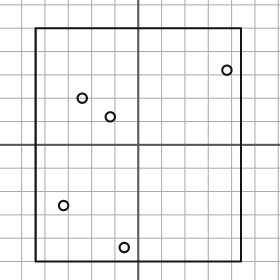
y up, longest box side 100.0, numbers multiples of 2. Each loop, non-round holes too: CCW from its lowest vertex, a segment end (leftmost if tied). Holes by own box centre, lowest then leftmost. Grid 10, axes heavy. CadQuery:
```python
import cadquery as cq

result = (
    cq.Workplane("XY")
    .moveTo(-44.0, -50.0)
    .lineTo(44.0, -50.0)
    .lineTo(44.0, 50.0)
    .lineTo(-44.0, 50.0)
    .close()
    .moveTo(-6.0, -44.0)
    .circle(2.0)
    .moveTo(-32.0, -26.0)
    .circle(2.0)
    .moveTo(-12.0, 12.0)
    .circle(2.0)
    .moveTo(-24.0, 20.0)
    .circle(2.0)
    .moveTo(38.0, 32.0)
    .circle(2.0)
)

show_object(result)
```